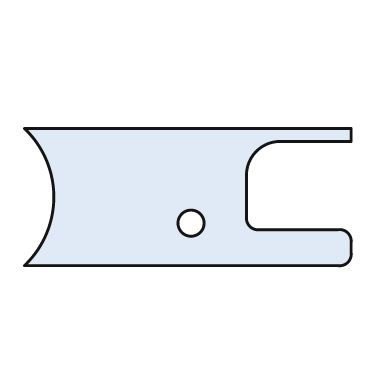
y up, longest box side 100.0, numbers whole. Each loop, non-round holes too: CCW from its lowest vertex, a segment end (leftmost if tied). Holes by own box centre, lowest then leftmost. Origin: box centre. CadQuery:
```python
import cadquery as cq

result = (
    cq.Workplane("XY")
    .moveTo(-50.0, -21.0)
    .lineTo(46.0, -21.0)
    .threePointArc((49.0, -20.0), (50.0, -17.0))
    .lineTo(50.0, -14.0)
    .threePointArc((49.0, -11.0), (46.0, -10.0))
    .lineTo(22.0, -10.0)
    .threePointArc((19.0, -9.0), (18.0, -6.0))
    .lineTo(18.0, 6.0)
    .threePointArc((21.0, 14.0), (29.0, 17.0))
    .lineTo(50.0, 17.0)
    .lineTo(50.0, 21.0)
    .lineTo(-50.0, 21.0)
    .threePointArc((-41.0, 0.0), (-50.0, -21.0))
    .close()
    .moveTo(1.0, -8.0)
    .circle(4.0)
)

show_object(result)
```